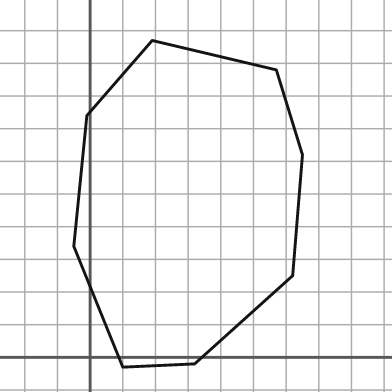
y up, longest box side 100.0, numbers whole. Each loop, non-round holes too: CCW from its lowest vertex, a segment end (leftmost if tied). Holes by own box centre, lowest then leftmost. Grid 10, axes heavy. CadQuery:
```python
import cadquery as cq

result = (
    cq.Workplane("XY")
    .moveTo(10.0, -3.0)
    .lineTo(32.0, -2.0)
    .lineTo(62.0, 25.0)
    .lineTo(65.0, 62.0)
    .lineTo(57.0, 88.0)
    .lineTo(19.0, 97.0)
    .lineTo(-1.0, 74.0)
    .lineTo(-5.0, 34.0)
    .close()
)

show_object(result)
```